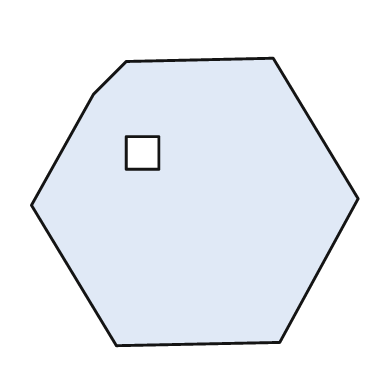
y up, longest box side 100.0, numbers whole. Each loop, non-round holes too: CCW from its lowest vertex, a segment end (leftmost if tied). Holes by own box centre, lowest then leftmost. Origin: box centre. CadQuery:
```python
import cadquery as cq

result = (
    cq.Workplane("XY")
    .moveTo(-24.0, -44.0)
    .lineTo(26.0, -43.0)
    .lineTo(50.0, 1.0)
    .lineTo(24.0, 44.0)
    .lineTo(-21.0, 43.0)
    .lineTo(-31.0, 33.0)
    .lineTo(-50.0, -1.0)
    .close()
    .moveTo(-21.0, 10.0)
    .lineTo(-11.0, 10.0)
    .lineTo(-11.0, 20.0)
    .lineTo(-21.0, 20.0)
    .close()
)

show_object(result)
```